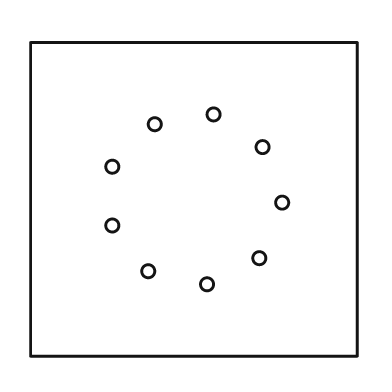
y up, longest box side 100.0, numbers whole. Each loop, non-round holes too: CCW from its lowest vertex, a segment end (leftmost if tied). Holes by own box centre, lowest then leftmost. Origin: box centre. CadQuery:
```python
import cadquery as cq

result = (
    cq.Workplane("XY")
    .moveTo(-50.0, -48.0)
    .lineTo(50.0, -48.0)
    .lineTo(50.0, 48.0)
    .lineTo(-50.0, 48.0)
    .close()
    .moveTo(4.0, -26.0)
    .circle(2.0)
    .moveTo(-14.0, -22.0)
    .circle(2.0)
    .moveTo(20.0, -18.0)
    .circle(2.0)
    .moveTo(-25.0, -8.0)
    .circle(2.0)
    .moveTo(27.0, -1.0)
    .circle(2.0)
    .moveTo(-25.0, 10.0)
    .circle(2.0)
    .moveTo(21.0, 16.0)
    .circle(2.0)
    .moveTo(-12.0, 23.0)
    .circle(2.0)
    .moveTo(6.0, 26.0)
    .circle(2.0)
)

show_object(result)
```